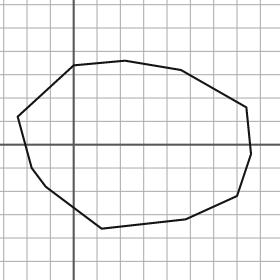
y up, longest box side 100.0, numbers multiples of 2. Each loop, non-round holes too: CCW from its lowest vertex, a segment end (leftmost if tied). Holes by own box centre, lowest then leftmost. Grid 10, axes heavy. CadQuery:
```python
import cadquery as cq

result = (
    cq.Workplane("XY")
    .moveTo(12.0, -36.0)
    .lineTo(48.0, -32.0)
    .lineTo(70.0, -22.0)
    .lineTo(76.0, -4.0)
    .lineTo(74.0, 16.0)
    .lineTo(46.0, 32.0)
    .lineTo(22.0, 36.0)
    .lineTo(0.0, 34.0)
    .lineTo(-24.0, 12.0)
    .lineTo(-18.0, -10.0)
    .lineTo(-12.0, -18.0)
    .close()
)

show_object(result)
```